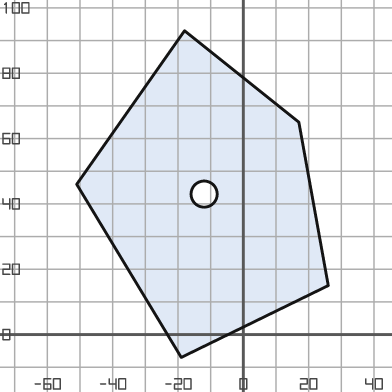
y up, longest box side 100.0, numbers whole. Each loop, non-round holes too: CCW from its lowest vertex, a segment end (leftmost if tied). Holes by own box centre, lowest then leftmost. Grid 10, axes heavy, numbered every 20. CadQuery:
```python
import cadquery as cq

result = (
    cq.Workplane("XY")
    .moveTo(-19.0, -7.0)
    .lineTo(26.0, 15.0)
    .lineTo(17.0, 65.0)
    .lineTo(-18.0, 93.0)
    .lineTo(-51.0, 46.0)
    .close()
    .moveTo(-12.0, 43.0)
    .circle(4.0)
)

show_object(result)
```